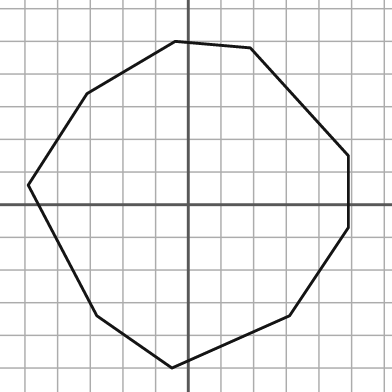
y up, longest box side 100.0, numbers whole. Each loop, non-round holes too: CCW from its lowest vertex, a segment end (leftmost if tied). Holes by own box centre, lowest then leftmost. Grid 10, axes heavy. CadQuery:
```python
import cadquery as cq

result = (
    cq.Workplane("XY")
    .moveTo(-5.0, -50.0)
    .lineTo(31.0, -34.0)
    .lineTo(49.0, -7.0)
    .lineTo(49.0, 15.0)
    .lineTo(19.0, 48.0)
    .lineTo(-4.0, 50.0)
    .lineTo(-31.0, 34.0)
    .lineTo(-49.0, 6.0)
    .lineTo(-28.0, -34.0)
    .close()
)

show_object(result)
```